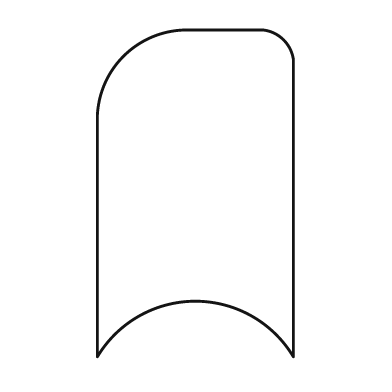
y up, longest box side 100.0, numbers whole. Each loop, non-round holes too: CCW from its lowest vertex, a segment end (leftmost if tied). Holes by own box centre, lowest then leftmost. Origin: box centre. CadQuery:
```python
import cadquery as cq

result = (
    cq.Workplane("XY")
    .moveTo(-30.0, -50.0)
    .threePointArc((0.0, -33.0), (30.0, -50.0))
    .lineTo(30.0, 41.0)
    .threePointArc((27.0, 47.0), (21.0, 50.0))
    .lineTo(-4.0, 50.0)
    .threePointArc((-22.0, 42.0), (-30.0, 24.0))
    .close()
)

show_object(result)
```